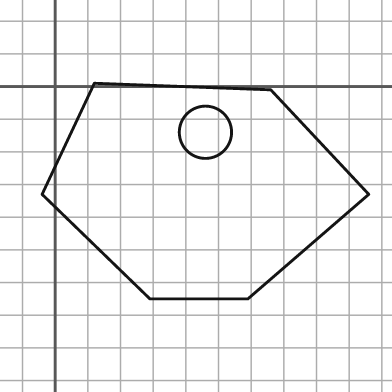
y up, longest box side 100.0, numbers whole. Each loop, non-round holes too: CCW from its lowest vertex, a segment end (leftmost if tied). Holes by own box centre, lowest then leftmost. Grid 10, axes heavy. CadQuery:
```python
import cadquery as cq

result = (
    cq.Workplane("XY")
    .moveTo(29.0, -65.0)
    .lineTo(59.0, -65.0)
    .lineTo(96.0, -33.0)
    .lineTo(66.0, -1.0)
    .lineTo(12.0, 1.0)
    .lineTo(-4.0, -33.0)
    .close()
    .moveTo(46.0, -14.0)
    .circle(8.0)
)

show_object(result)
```